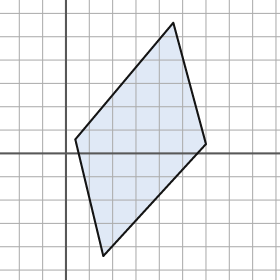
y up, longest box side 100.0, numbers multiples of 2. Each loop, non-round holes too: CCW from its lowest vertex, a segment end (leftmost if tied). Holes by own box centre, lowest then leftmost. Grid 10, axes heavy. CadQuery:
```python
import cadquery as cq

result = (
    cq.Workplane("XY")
    .moveTo(16.0, -44.0)
    .lineTo(60.0, 4.0)
    .lineTo(46.0, 56.0)
    .lineTo(4.0, 6.0)
    .close()
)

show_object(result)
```